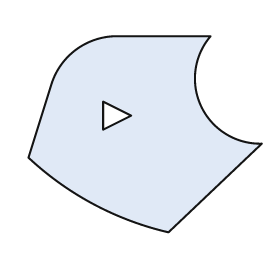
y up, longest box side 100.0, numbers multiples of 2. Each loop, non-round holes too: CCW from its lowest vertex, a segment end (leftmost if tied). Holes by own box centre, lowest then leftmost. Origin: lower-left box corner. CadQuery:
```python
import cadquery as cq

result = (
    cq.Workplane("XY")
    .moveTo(60.0, 0.0)
    .lineTo(100.0, 38.0)
    .threePointArc((74.0, 54.0), (78.0, 84.0))
    .lineTo(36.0, 84.0)
    .threePointArc((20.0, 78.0), (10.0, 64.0))
    .lineTo(0.0, 32.0)
    .threePointArc((28.0, 12.0), (60.0, 0.0))
    .close()
    .moveTo(32.0, 44.0)
    .lineTo(44.0, 50.0)
    .lineTo(32.0, 56.0)
    .close()
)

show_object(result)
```